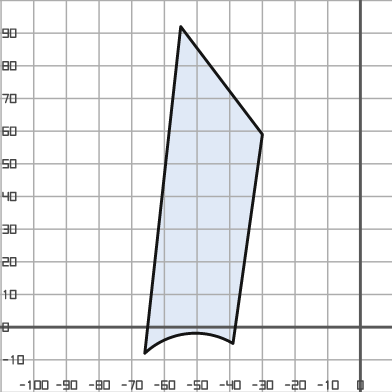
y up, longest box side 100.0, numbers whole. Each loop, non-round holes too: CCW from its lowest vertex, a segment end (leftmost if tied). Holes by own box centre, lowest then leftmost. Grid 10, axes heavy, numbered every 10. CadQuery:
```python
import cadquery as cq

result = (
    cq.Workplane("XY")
    .moveTo(-66.0, -8.0)
    .threePointArc((-53.0, -2.0), (-39.0, -5.0))
    .lineTo(-30.0, 59.0)
    .lineTo(-55.0, 92.0)
    .close()
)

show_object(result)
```